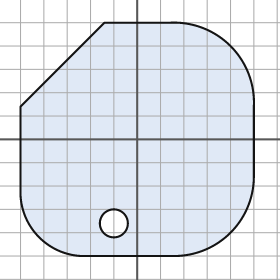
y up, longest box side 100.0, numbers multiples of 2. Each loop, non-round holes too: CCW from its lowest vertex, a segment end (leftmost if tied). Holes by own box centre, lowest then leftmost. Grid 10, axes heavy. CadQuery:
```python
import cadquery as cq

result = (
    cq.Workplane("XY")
    .moveTo(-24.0, -50.0)
    .lineTo(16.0, -50.0)
    .threePointArc((40.0, -40.0), (50.0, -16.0))
    .lineTo(50.0, 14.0)
    .threePointArc((40.0, 40.0), (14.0, 50.0))
    .lineTo(-14.0, 50.0)
    .lineTo(-50.0, 14.0)
    .lineTo(-50.0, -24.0)
    .threePointArc((-42.0, -42.0), (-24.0, -50.0))
    .close()
    .moveTo(-10.0, -36.0)
    .circle(6.0)
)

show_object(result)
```